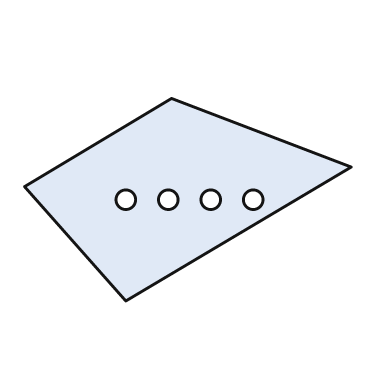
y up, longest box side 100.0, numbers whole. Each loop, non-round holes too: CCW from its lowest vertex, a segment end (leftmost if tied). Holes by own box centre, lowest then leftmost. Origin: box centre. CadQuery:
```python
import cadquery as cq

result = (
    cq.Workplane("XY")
    .moveTo(-19.0, -31.0)
    .lineTo(50.0, 10.0)
    .lineTo(-5.0, 31.0)
    .lineTo(-50.0, 4.0)
    .close()
    .moveTo(-19.0, 0.0)
    .circle(3.0)
    .moveTo(-6.0, 0.0)
    .circle(3.0)
    .moveTo(7.0, 0.0)
    .circle(3.0)
    .moveTo(20.0, 0.0)
    .circle(3.0)
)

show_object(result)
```